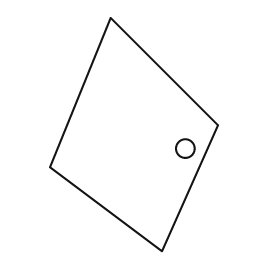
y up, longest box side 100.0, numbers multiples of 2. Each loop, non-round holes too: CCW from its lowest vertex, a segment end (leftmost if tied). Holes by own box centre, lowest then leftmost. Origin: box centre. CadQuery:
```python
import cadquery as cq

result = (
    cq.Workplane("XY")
    .moveTo(12.0, -50.0)
    .lineTo(36.0, 4.0)
    .lineTo(-10.0, 50.0)
    .lineTo(-36.0, -14.0)
    .close()
    .moveTo(22.0, -6.0)
    .circle(4.0)
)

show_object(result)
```